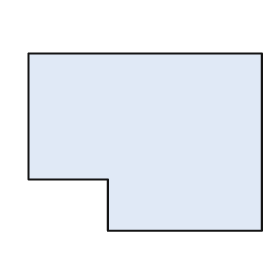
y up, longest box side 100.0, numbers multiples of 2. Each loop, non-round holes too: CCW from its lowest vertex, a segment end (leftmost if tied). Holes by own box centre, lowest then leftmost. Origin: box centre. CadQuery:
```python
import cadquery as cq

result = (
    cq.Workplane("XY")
    .moveTo(-16.0, -38.0)
    .lineTo(50.0, -38.0)
    .lineTo(50.0, 38.0)
    .lineTo(-50.0, 38.0)
    .lineTo(-50.0, -16.0)
    .lineTo(-16.0, -16.0)
    .close()
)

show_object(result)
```